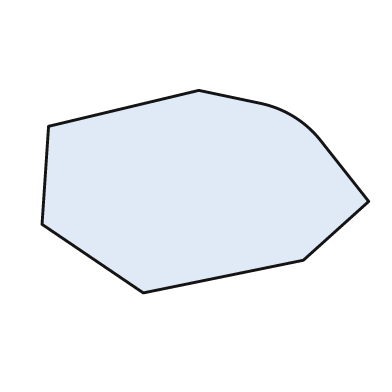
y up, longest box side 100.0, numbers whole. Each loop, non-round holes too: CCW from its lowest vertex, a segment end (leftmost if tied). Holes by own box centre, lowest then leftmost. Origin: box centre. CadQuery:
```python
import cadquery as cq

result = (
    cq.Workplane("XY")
    .moveTo(-19.0, -31.0)
    .lineTo(30.0, -21.0)
    .lineTo(50.0, -3.0)
    .lineTo(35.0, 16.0)
    .threePointArc((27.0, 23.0), (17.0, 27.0))
    .lineTo(-2.0, 31.0)
    .lineTo(-48.0, 20.0)
    .lineTo(-50.0, -10.0)
    .close()
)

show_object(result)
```